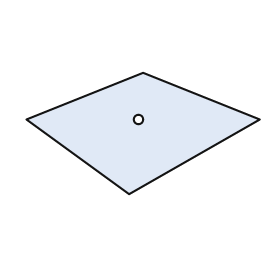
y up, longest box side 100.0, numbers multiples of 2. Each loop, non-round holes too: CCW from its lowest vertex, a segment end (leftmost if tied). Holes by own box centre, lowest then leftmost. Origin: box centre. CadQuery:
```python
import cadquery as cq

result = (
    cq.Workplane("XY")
    .moveTo(-6.0, -26.0)
    .lineTo(50.0, 6.0)
    .lineTo(0.0, 26.0)
    .lineTo(-50.0, 6.0)
    .close()
    .moveTo(-2.0, 6.0)
    .circle(2.0)
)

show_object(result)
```